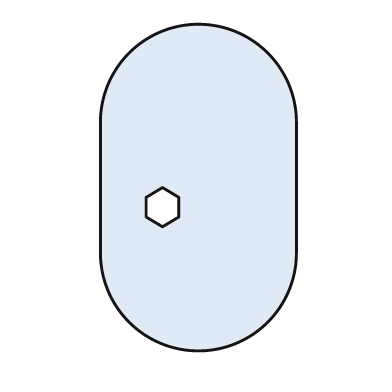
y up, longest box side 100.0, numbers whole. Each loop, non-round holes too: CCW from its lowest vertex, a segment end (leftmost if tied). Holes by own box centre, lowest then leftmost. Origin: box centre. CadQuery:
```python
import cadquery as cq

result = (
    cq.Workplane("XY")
    .moveTo(-30.0, -20.0)
    .threePointArc((0.0, -50.0), (30.0, -20.0))
    .lineTo(30.0, 20.0)
    .threePointArc((0.0, 50.0), (-30.0, 20.0))
    .close()
    .moveTo(-11.0, -12.0)
    .lineTo(-6.0, -9.0)
    .lineTo(-6.0, -3.0)
    .lineTo(-11.0, 0.0)
    .lineTo(-16.0, -3.0)
    .lineTo(-16.0, -9.0)
    .close()
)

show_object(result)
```